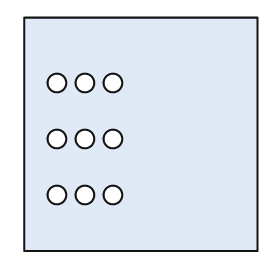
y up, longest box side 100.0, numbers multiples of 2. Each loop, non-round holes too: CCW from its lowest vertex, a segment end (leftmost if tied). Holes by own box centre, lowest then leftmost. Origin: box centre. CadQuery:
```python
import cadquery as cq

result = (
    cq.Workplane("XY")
    .moveTo(-50.0, -50.0)
    .lineTo(50.0, -50.0)
    .lineTo(50.0, 50.0)
    .lineTo(-50.0, 50.0)
    .close()
    .moveTo(-36.0, -26.0)
    .circle(4.0)
    .moveTo(-24.0, -26.0)
    .circle(4.0)
    .moveTo(-12.0, -26.0)
    .circle(4.0)
    .moveTo(-36.0, -2.0)
    .circle(4.0)
    .moveTo(-24.0, -2.0)
    .circle(4.0)
    .moveTo(-12.0, -2.0)
    .circle(4.0)
    .moveTo(-36.0, 22.0)
    .circle(4.0)
    .moveTo(-24.0, 22.0)
    .circle(4.0)
    .moveTo(-12.0, 22.0)
    .circle(4.0)
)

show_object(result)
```